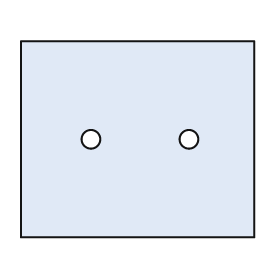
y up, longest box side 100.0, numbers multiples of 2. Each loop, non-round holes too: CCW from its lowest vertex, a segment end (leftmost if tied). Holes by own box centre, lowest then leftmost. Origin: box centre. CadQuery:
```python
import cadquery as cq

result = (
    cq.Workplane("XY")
    .moveTo(-50.0, -42.0)
    .lineTo(50.0, -42.0)
    .lineTo(50.0, 42.0)
    .lineTo(-50.0, 42.0)
    .close()
    .moveTo(-20.0, 0.0)
    .circle(4.0)
    .moveTo(22.0, 0.0)
    .circle(4.0)
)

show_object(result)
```